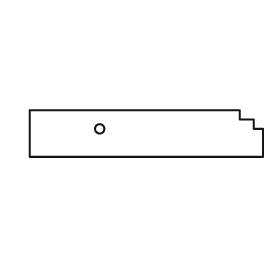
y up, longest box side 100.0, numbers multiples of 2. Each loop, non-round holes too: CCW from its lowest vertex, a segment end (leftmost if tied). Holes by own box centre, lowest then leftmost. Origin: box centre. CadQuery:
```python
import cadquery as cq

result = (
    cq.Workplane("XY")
    .moveTo(-50.0, -10.0)
    .lineTo(50.0, -10.0)
    .lineTo(50.0, 2.0)
    .lineTo(46.0, 2.0)
    .lineTo(46.0, 6.0)
    .lineTo(40.0, 6.0)
    .lineTo(40.0, 10.0)
    .lineTo(-50.0, 10.0)
    .close()
    .moveTo(-20.0, 2.0)
    .circle(2.0)
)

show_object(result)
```